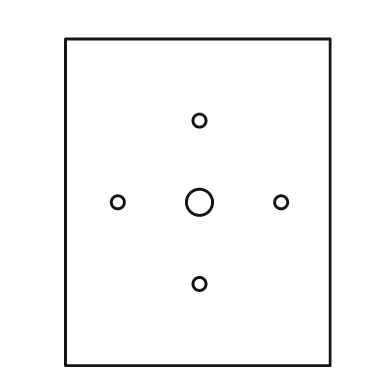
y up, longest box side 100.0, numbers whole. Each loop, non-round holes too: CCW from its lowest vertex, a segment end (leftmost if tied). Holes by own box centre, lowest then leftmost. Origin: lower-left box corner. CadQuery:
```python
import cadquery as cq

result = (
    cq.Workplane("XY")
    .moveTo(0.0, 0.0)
    .lineTo(81.0, 0.0)
    .lineTo(81.0, 100.0)
    .lineTo(0.0, 100.0)
    .close()
    .moveTo(41.0, 25.0)
    .circle(2.0)
    .moveTo(16.0, 50.0)
    .circle(2.0)
    .moveTo(41.0, 50.0)
    .circle(4.0)
    .moveTo(66.0, 50.0)
    .circle(2.0)
    .moveTo(41.0, 75.0)
    .circle(2.0)
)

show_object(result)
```